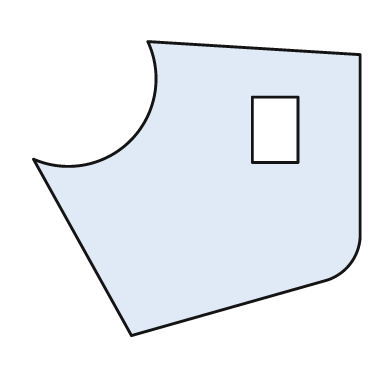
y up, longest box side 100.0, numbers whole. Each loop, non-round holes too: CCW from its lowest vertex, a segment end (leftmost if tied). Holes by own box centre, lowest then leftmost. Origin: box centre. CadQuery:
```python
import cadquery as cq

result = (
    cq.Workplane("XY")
    .moveTo(-20.0, -45.0)
    .lineTo(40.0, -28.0)
    .threePointArc((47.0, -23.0), (50.0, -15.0))
    .lineTo(50.0, 41.0)
    .lineTo(-15.0, 45.0)
    .threePointArc((-20.0, 15.0), (-50.0, 9.0))
    .close()
    .moveTo(17.0, 8.0)
    .lineTo(31.0, 8.0)
    .lineTo(31.0, 28.0)
    .lineTo(17.0, 28.0)
    .close()
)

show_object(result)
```